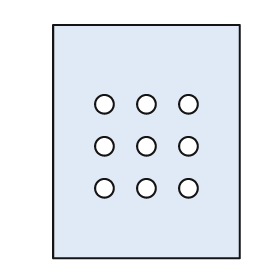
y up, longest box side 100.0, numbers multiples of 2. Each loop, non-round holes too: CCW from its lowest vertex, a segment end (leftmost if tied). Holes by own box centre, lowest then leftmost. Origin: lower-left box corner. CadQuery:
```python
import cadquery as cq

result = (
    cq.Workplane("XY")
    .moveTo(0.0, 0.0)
    .lineTo(80.0, 0.0)
    .lineTo(80.0, 100.0)
    .lineTo(0.0, 100.0)
    .close()
    .moveTo(22.0, 30.0)
    .circle(4.0)
    .moveTo(40.0, 30.0)
    .circle(4.0)
    .moveTo(58.0, 30.0)
    .circle(4.0)
    .moveTo(22.0, 48.0)
    .circle(4.0)
    .moveTo(40.0, 48.0)
    .circle(4.0)
    .moveTo(58.0, 48.0)
    .circle(4.0)
    .moveTo(22.0, 66.0)
    .circle(4.0)
    .moveTo(40.0, 66.0)
    .circle(4.0)
    .moveTo(58.0, 66.0)
    .circle(4.0)
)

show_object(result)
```